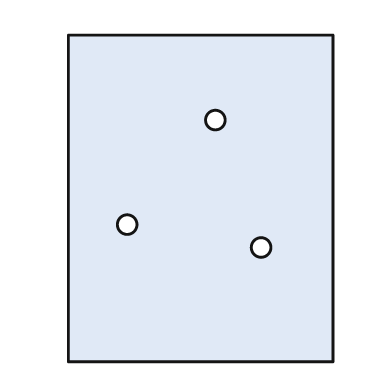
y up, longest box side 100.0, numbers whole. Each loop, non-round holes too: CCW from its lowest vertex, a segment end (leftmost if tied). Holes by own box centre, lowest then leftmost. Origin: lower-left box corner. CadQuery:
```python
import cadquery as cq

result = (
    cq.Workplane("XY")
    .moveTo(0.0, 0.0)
    .lineTo(81.0, 0.0)
    .lineTo(81.0, 100.0)
    .lineTo(0.0, 100.0)
    .close()
    .moveTo(59.0, 35.0)
    .circle(3.0)
    .moveTo(18.0, 42.0)
    .circle(3.0)
    .moveTo(45.0, 74.0)
    .circle(3.0)
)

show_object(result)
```